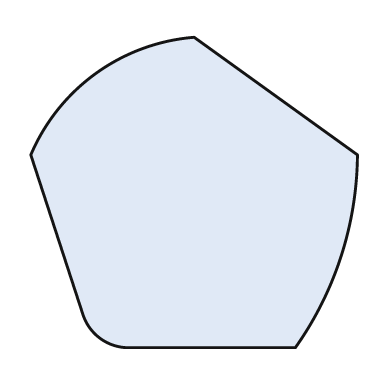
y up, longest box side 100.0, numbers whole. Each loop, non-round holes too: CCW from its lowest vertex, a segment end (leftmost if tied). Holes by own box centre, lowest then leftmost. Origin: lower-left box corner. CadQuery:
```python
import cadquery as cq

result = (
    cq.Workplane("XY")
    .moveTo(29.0, 0.0)
    .lineTo(81.0, 0.0)
    .threePointArc((95.0, 28.0), (100.0, 59.0))
    .lineTo(50.0, 95.0)
    .threePointArc((20.0, 84.0), (0.0, 59.0))
    .lineTo(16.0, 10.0)
    .threePointArc((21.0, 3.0), (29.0, 0.0))
    .close()
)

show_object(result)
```